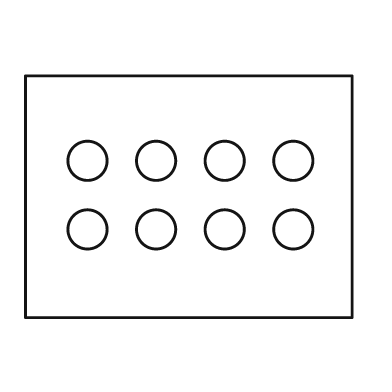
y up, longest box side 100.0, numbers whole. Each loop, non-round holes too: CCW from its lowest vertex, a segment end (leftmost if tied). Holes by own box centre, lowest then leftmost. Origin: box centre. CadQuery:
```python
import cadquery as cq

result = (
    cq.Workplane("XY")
    .moveTo(-50.0, -37.0)
    .lineTo(50.0, -37.0)
    .lineTo(50.0, 37.0)
    .lineTo(-50.0, 37.0)
    .close()
    .moveTo(-31.0, -10.0)
    .circle(6.0)
    .moveTo(-10.0, -10.0)
    .circle(6.0)
    .moveTo(11.0, -10.0)
    .circle(6.0)
    .moveTo(32.0, -10.0)
    .circle(6.0)
    .moveTo(-31.0, 11.0)
    .circle(6.0)
    .moveTo(-10.0, 11.0)
    .circle(6.0)
    .moveTo(11.0, 11.0)
    .circle(6.0)
    .moveTo(32.0, 11.0)
    .circle(6.0)
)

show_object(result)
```